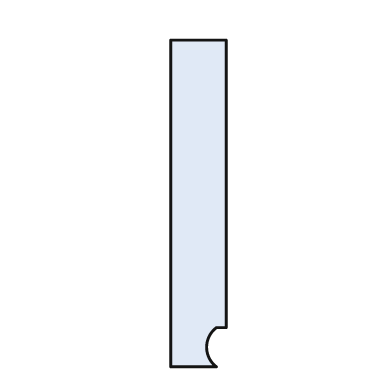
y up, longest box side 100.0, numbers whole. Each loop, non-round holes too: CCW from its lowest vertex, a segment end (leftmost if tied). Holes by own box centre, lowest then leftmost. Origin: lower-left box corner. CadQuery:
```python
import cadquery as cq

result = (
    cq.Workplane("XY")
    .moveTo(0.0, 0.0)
    .lineTo(14.0, 0.0)
    .threePointArc((11.0, 6.0), (14.0, 12.0))
    .lineTo(17.0, 12.0)
    .lineTo(17.0, 100.0)
    .lineTo(0.0, 100.0)
    .close()
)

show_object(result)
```